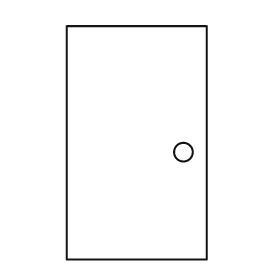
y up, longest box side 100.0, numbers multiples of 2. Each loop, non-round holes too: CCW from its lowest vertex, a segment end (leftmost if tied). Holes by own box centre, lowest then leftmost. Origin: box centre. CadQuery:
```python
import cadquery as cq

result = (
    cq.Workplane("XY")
    .moveTo(-30.0, -50.0)
    .lineTo(30.0, -50.0)
    .lineTo(30.0, 50.0)
    .lineTo(-30.0, 50.0)
    .close()
    .moveTo(20.0, -4.0)
    .circle(4.0)
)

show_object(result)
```